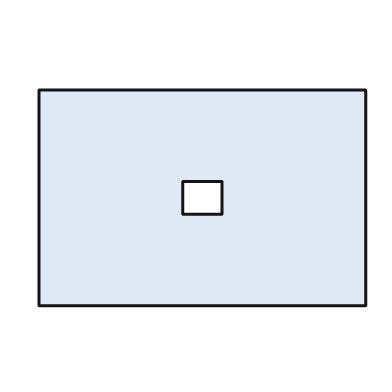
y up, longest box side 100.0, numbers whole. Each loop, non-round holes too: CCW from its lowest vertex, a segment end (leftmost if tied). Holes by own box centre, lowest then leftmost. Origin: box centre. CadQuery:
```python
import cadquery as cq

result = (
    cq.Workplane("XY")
    .moveTo(-50.0, -33.0)
    .lineTo(50.0, -33.0)
    .lineTo(50.0, 33.0)
    .lineTo(-50.0, 33.0)
    .close()
    .moveTo(-6.0, -5.0)
    .lineTo(6.0, -5.0)
    .lineTo(6.0, 5.0)
    .lineTo(-6.0, 5.0)
    .close()
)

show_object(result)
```